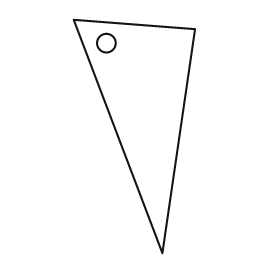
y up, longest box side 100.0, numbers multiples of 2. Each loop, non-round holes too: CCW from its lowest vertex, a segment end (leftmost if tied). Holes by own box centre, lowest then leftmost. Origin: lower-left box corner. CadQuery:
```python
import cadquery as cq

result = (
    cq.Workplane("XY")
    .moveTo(38.0, 0.0)
    .lineTo(52.0, 96.0)
    .lineTo(0.0, 100.0)
    .close()
    .moveTo(14.0, 90.0)
    .circle(4.0)
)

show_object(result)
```